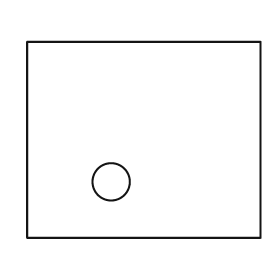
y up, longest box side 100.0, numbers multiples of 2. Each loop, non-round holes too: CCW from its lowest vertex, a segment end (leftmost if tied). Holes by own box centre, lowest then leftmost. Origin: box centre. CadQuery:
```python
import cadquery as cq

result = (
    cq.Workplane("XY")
    .moveTo(-50.0, -42.0)
    .lineTo(50.0, -42.0)
    .lineTo(50.0, 42.0)
    .lineTo(-50.0, 42.0)
    .close()
    .moveTo(-14.0, -18.0)
    .circle(8.0)
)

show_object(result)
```